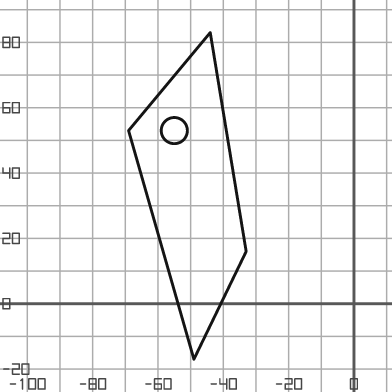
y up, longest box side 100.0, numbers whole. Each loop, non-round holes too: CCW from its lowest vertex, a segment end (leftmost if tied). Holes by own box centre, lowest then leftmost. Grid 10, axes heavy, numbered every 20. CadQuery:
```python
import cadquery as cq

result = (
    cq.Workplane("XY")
    .moveTo(-49.0, -17.0)
    .lineTo(-33.0, 16.0)
    .lineTo(-44.0, 83.0)
    .lineTo(-69.0, 53.0)
    .close()
    .moveTo(-55.0, 53.0)
    .circle(4.0)
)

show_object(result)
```